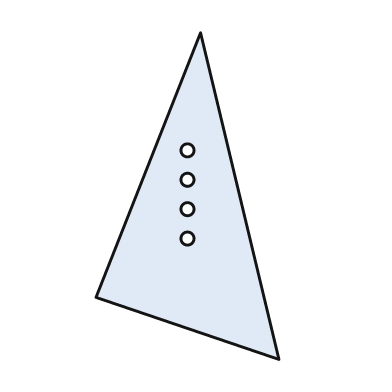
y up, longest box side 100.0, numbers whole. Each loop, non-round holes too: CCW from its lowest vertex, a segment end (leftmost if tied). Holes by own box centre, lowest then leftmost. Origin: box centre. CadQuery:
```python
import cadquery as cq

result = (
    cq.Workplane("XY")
    .moveTo(28.0, -50.0)
    .lineTo(4.0, 50.0)
    .lineTo(-28.0, -31.0)
    .close()
    .moveTo(0.0, -13.0)
    .circle(2.0)
    .moveTo(0.0, -4.0)
    .circle(2.0)
    .moveTo(0.0, 5.0)
    .circle(2.0)
    .moveTo(0.0, 14.0)
    .circle(2.0)
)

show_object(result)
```